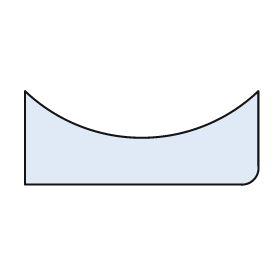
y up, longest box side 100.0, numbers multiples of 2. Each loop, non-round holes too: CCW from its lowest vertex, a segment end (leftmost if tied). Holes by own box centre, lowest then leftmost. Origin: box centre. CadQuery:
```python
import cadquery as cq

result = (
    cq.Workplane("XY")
    .moveTo(-50.0, -20.0)
    .lineTo(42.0, -20.0)
    .threePointArc((48.0, -18.0), (50.0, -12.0))
    .lineTo(50.0, 20.0)
    .threePointArc((0.0, 0.0), (-50.0, 20.0))
    .close()
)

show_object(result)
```